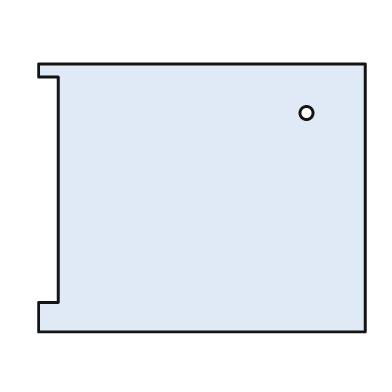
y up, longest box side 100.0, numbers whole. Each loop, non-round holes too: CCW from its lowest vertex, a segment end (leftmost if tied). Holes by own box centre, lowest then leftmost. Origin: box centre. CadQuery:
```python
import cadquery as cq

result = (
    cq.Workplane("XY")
    .moveTo(-50.0, -41.0)
    .lineTo(50.0, -41.0)
    .lineTo(50.0, 41.0)
    .lineTo(-50.0, 41.0)
    .lineTo(-50.0, 37.0)
    .lineTo(-44.0, 37.0)
    .lineTo(-44.0, -32.0)
    .lineTo(-50.0, -32.0)
    .close()
    .moveTo(32.0, 26.0)
    .circle(2.0)
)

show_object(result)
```